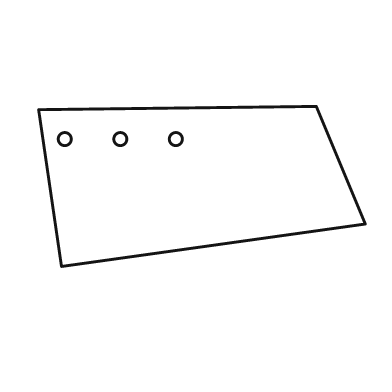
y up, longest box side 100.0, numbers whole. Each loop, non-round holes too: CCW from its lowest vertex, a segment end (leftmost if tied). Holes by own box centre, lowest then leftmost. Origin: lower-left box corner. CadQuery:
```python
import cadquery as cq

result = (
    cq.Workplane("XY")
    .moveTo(7.0, 0.0)
    .lineTo(100.0, 13.0)
    .lineTo(85.0, 49.0)
    .lineTo(0.0, 48.0)
    .close()
    .moveTo(8.0, 39.0)
    .circle(2.0)
    .moveTo(25.0, 39.0)
    .circle(2.0)
    .moveTo(42.0, 39.0)
    .circle(2.0)
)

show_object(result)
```